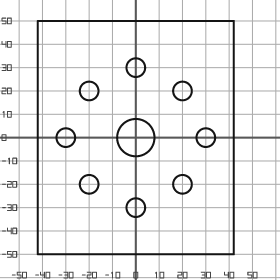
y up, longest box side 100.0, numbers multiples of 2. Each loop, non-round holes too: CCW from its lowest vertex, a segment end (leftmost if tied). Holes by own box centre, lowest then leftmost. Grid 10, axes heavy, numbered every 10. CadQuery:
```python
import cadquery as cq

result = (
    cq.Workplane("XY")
    .moveTo(-42.0, -50.0)
    .lineTo(42.0, -50.0)
    .lineTo(42.0, 50.0)
    .lineTo(-42.0, 50.0)
    .close()
    .moveTo(0.0, -30.0)
    .circle(4.0)
    .moveTo(-20.0, -20.0)
    .circle(4.0)
    .moveTo(20.0, -20.0)
    .circle(4.0)
    .moveTo(-30.0, 0.0)
    .circle(4.0)
    .moveTo(0.0, 0.0)
    .circle(8.0)
    .moveTo(30.0, 0.0)
    .circle(4.0)
    .moveTo(-20.0, 20.0)
    .circle(4.0)
    .moveTo(20.0, 20.0)
    .circle(4.0)
    .moveTo(0.0, 30.0)
    .circle(4.0)
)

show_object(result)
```